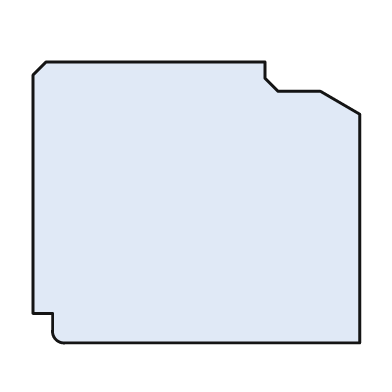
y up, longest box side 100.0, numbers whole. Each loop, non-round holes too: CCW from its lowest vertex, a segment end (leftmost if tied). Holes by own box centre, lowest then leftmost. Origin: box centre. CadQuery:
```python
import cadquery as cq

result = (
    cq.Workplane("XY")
    .moveTo(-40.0, -43.0)
    .lineTo(50.0, -43.0)
    .lineTo(50.0, 27.0)
    .lineTo(38.0, 34.0)
    .lineTo(25.0, 34.0)
    .lineTo(21.0, 38.0)
    .lineTo(21.0, 43.0)
    .lineTo(-46.0, 43.0)
    .lineTo(-50.0, 39.0)
    .lineTo(-50.0, -34.0)
    .lineTo(-44.0, -34.0)
    .lineTo(-44.0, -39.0)
    .threePointArc((-43.0, -42.0), (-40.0, -43.0))
    .close()
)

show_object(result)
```